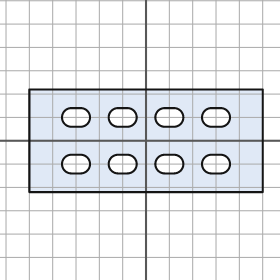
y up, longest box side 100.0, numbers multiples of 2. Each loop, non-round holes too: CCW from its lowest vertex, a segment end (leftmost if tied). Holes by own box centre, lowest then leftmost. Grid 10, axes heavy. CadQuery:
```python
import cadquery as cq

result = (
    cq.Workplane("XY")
    .moveTo(-50.0, -22.0)
    .lineTo(50.0, -22.0)
    .lineTo(50.0, 22.0)
    .lineTo(-50.0, 22.0)
    .close()
    .moveTo(-32.0, -14.0)
    .lineTo(-28.0, -14.0)
    .threePointArc((-24.0, -10.0), (-28.0, -6.0))
    .lineTo(-32.0, -6.0)
    .threePointArc((-36.0, -10.0), (-32.0, -14.0))
    .close()
    .moveTo(-12.0, -14.0)
    .lineTo(-8.0, -14.0)
    .threePointArc((-4.0, -10.0), (-8.0, -6.0))
    .lineTo(-12.0, -6.0)
    .threePointArc((-16.0, -10.0), (-12.0, -14.0))
    .close()
    .moveTo(8.0, -14.0)
    .lineTo(12.0, -14.0)
    .threePointArc((16.0, -10.0), (12.0, -6.0))
    .lineTo(8.0, -6.0)
    .threePointArc((4.0, -10.0), (8.0, -14.0))
    .close()
    .moveTo(28.0, -14.0)
    .lineTo(32.0, -14.0)
    .threePointArc((36.0, -10.0), (32.0, -6.0))
    .lineTo(28.0, -6.0)
    .threePointArc((24.0, -10.0), (28.0, -14.0))
    .close()
    .moveTo(-32.0, 6.0)
    .lineTo(-28.0, 6.0)
    .threePointArc((-24.0, 10.0), (-28.0, 14.0))
    .lineTo(-32.0, 14.0)
    .threePointArc((-36.0, 10.0), (-32.0, 6.0))
    .close()
    .moveTo(-12.0, 6.0)
    .lineTo(-8.0, 6.0)
    .threePointArc((-4.0, 10.0), (-8.0, 14.0))
    .lineTo(-12.0, 14.0)
    .threePointArc((-16.0, 10.0), (-12.0, 6.0))
    .close()
    .moveTo(8.0, 6.0)
    .lineTo(12.0, 6.0)
    .threePointArc((16.0, 10.0), (12.0, 14.0))
    .lineTo(8.0, 14.0)
    .threePointArc((4.0, 10.0), (8.0, 6.0))
    .close()
    .moveTo(28.0, 6.0)
    .lineTo(32.0, 6.0)
    .threePointArc((36.0, 10.0), (32.0, 14.0))
    .lineTo(28.0, 14.0)
    .threePointArc((24.0, 10.0), (28.0, 6.0))
    .close()
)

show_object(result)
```